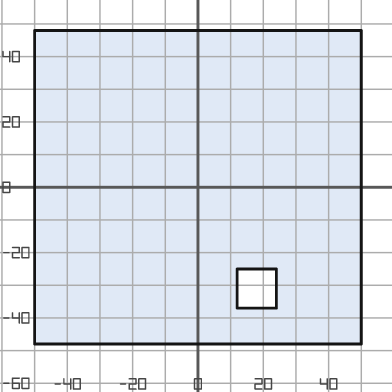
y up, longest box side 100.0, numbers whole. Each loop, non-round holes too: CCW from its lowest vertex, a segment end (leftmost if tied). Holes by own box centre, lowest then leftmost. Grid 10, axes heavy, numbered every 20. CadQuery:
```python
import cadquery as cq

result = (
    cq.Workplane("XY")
    .moveTo(-50.0, -48.0)
    .lineTo(50.0, -48.0)
    .lineTo(50.0, 48.0)
    .lineTo(-50.0, 48.0)
    .close()
    .moveTo(12.0, -37.0)
    .lineTo(24.0, -37.0)
    .lineTo(24.0, -25.0)
    .lineTo(12.0, -25.0)
    .close()
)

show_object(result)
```